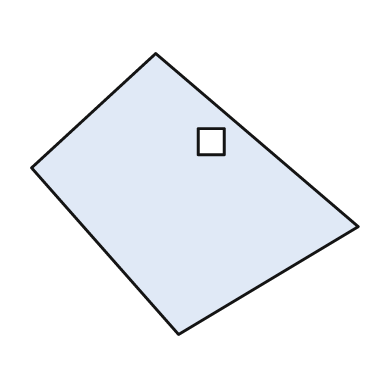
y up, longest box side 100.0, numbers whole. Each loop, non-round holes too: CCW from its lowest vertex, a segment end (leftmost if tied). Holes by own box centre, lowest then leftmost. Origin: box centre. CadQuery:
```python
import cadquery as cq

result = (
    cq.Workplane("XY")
    .moveTo(-5.0, -43.0)
    .lineTo(50.0, -10.0)
    .lineTo(-12.0, 43.0)
    .lineTo(-50.0, 8.0)
    .close()
    .moveTo(1.0, 12.0)
    .lineTo(9.0, 12.0)
    .lineTo(9.0, 20.0)
    .lineTo(1.0, 20.0)
    .close()
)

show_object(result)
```